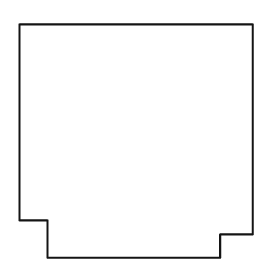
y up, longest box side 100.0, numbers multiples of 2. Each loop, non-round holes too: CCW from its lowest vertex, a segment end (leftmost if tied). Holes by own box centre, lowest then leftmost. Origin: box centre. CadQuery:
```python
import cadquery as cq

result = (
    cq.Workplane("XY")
    .moveTo(-38.0, -50.0)
    .lineTo(36.0, -50.0)
    .lineTo(36.0, -40.0)
    .lineTo(50.0, -40.0)
    .lineTo(50.0, 50.0)
    .lineTo(-50.0, 50.0)
    .lineTo(-50.0, -34.0)
    .lineTo(-38.0, -34.0)
    .close()
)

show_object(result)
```